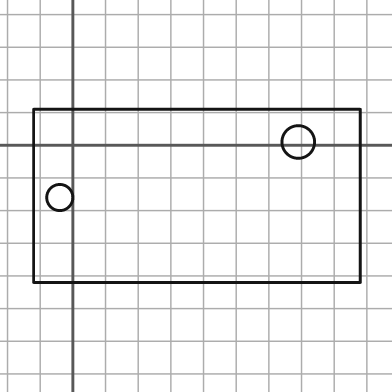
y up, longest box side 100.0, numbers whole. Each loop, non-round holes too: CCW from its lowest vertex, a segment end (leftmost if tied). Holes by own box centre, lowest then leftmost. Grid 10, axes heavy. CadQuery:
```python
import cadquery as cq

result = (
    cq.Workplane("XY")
    .moveTo(-12.0, -42.0)
    .lineTo(88.0, -42.0)
    .lineTo(88.0, 11.0)
    .lineTo(-12.0, 11.0)
    .close()
    .moveTo(-4.0, -16.0)
    .circle(4.0)
    .moveTo(69.0, 1.0)
    .circle(5.0)
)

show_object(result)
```